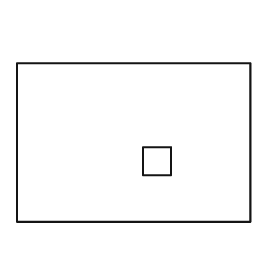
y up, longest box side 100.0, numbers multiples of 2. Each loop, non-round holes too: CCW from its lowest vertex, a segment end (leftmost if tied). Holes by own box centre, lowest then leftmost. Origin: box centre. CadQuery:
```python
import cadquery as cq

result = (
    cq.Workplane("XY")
    .moveTo(-50.0, -34.0)
    .lineTo(50.0, -34.0)
    .lineTo(50.0, 34.0)
    .lineTo(-50.0, 34.0)
    .close()
    .moveTo(4.0, -14.0)
    .lineTo(16.0, -14.0)
    .lineTo(16.0, -2.0)
    .lineTo(4.0, -2.0)
    .close()
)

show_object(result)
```